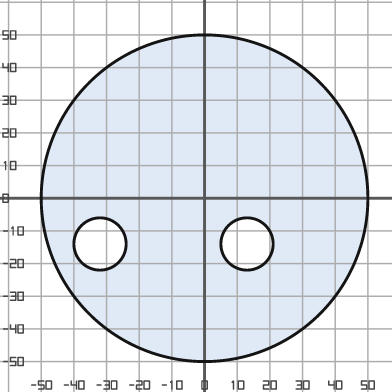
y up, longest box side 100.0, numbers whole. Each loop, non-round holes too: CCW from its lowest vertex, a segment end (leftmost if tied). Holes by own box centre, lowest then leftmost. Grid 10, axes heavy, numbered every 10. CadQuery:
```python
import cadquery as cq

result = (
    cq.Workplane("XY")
    .moveTo(0.0, 0.0)
    .circle(50.0)
    .moveTo(-32.0, -14.0)
    .circle(8.0)
    .moveTo(13.0, -14.0)
    .circle(8.0)
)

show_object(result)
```